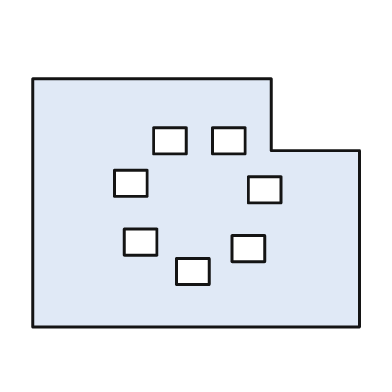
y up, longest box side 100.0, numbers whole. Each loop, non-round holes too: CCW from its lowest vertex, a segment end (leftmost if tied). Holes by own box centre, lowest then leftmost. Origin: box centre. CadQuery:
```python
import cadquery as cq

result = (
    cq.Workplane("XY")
    .moveTo(-50.0, -38.0)
    .lineTo(50.0, -38.0)
    .lineTo(50.0, 16.0)
    .lineTo(23.0, 16.0)
    .lineTo(23.0, 38.0)
    .lineTo(-50.0, 38.0)
    .close()
    .moveTo(-6.0, -25.0)
    .lineTo(4.0, -25.0)
    .lineTo(4.0, -17.0)
    .lineTo(-6.0, -17.0)
    .close()
    .moveTo(11.0, -18.0)
    .lineTo(21.0, -18.0)
    .lineTo(21.0, -10.0)
    .lineTo(11.0, -10.0)
    .close()
    .moveTo(-22.0, -16.0)
    .lineTo(-12.0, -16.0)
    .lineTo(-12.0, -8.0)
    .lineTo(-22.0, -8.0)
    .close()
    .moveTo(16.0, 0.0)
    .lineTo(26.0, 0.0)
    .lineTo(26.0, 8.0)
    .lineTo(16.0, 8.0)
    .close()
    .moveTo(-25.0, 2.0)
    .lineTo(-15.0, 2.0)
    .lineTo(-15.0, 10.0)
    .lineTo(-25.0, 10.0)
    .close()
    .moveTo(-13.0, 15.0)
    .lineTo(-3.0, 15.0)
    .lineTo(-3.0, 23.0)
    .lineTo(-13.0, 23.0)
    .close()
    .moveTo(5.0, 15.0)
    .lineTo(15.0, 15.0)
    .lineTo(15.0, 23.0)
    .lineTo(5.0, 23.0)
    .close()
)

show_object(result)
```